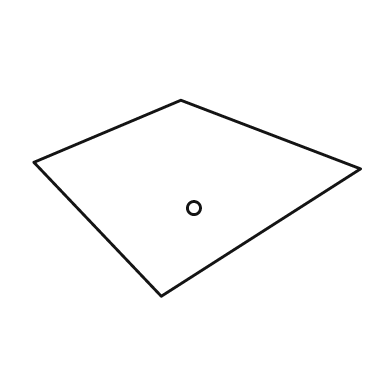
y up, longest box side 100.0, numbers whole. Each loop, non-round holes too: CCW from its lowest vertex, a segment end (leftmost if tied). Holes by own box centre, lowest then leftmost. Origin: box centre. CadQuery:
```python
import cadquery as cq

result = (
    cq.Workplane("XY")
    .moveTo(-11.0, -30.0)
    .lineTo(50.0, 9.0)
    .lineTo(-5.0, 30.0)
    .lineTo(-50.0, 11.0)
    .close()
    .moveTo(-1.0, -3.0)
    .circle(2.0)
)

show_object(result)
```